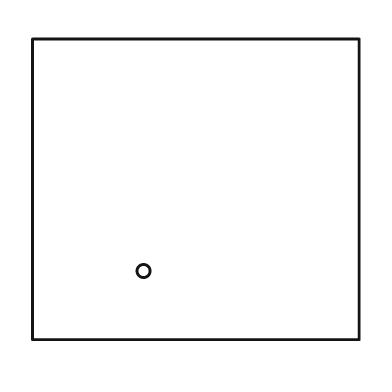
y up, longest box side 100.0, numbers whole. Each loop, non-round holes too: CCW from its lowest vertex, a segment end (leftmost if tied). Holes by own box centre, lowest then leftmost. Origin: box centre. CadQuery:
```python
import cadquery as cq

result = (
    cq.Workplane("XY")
    .moveTo(-50.0, -46.0)
    .lineTo(50.0, -46.0)
    .lineTo(50.0, 46.0)
    .lineTo(-50.0, 46.0)
    .close()
    .moveTo(-16.0, -25.0)
    .circle(2.0)
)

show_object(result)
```